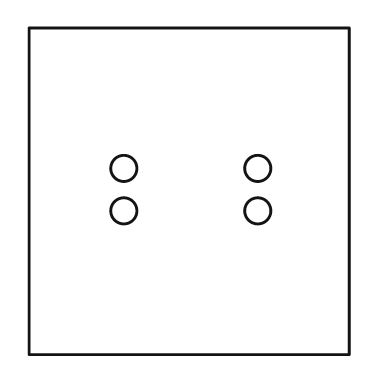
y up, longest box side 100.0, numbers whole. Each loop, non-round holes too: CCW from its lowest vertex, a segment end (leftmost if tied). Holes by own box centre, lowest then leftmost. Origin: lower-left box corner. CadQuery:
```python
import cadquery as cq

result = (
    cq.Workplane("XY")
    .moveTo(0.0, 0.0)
    .lineTo(98.0, 0.0)
    .lineTo(98.0, 100.0)
    .lineTo(0.0, 100.0)
    .close()
    .moveTo(29.0, 44.0)
    .circle(4.0)
    .moveTo(70.0, 44.0)
    .circle(4.0)
    .moveTo(29.0, 57.0)
    .circle(4.0)
    .moveTo(70.0, 57.0)
    .circle(4.0)
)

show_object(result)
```